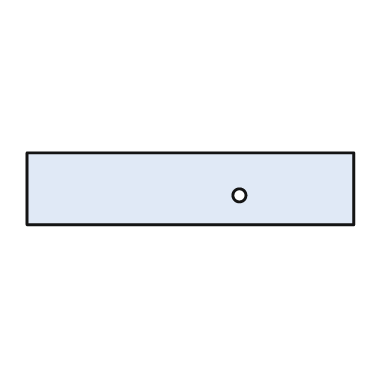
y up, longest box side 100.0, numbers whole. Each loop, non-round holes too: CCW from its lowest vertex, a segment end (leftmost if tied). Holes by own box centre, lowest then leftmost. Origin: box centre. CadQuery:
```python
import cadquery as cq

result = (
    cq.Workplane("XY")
    .moveTo(-50.0, -11.0)
    .lineTo(50.0, -11.0)
    .lineTo(50.0, 11.0)
    .lineTo(-50.0, 11.0)
    .close()
    .moveTo(15.0, -2.0)
    .circle(2.0)
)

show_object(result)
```